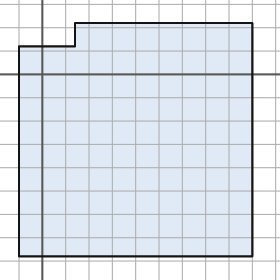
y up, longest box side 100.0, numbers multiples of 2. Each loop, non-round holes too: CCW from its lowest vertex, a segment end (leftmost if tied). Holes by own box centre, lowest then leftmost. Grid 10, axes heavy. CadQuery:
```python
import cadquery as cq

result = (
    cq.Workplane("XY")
    .moveTo(-10.0, -78.0)
    .lineTo(90.0, -78.0)
    .lineTo(90.0, 22.0)
    .lineTo(14.0, 22.0)
    .lineTo(14.0, 12.0)
    .lineTo(-10.0, 12.0)
    .close()
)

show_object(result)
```